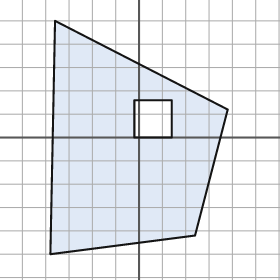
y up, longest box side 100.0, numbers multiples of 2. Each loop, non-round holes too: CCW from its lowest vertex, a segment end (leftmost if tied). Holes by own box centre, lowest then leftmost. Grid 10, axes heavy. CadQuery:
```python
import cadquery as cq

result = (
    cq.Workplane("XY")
    .moveTo(-38.0, -50.0)
    .lineTo(24.0, -42.0)
    .lineTo(38.0, 12.0)
    .lineTo(-36.0, 50.0)
    .close()
    .moveTo(-2.0, 0.0)
    .lineTo(14.0, 0.0)
    .lineTo(14.0, 16.0)
    .lineTo(-2.0, 16.0)
    .close()
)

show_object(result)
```